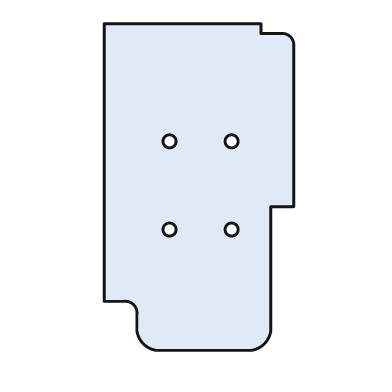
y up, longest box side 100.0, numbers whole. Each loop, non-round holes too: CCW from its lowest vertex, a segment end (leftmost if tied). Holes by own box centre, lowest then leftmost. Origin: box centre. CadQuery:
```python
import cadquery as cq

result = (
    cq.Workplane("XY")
    .moveTo(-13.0, -50.0)
    .lineTo(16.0, -50.0)
    .threePointArc((20.0, -48.0), (22.0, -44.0))
    .lineTo(22.0, -6.0)
    .lineTo(29.0, -6.0)
    .lineTo(29.0, 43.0)
    .threePointArc((28.0, 46.0), (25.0, 47.0))
    .lineTo(19.0, 47.0)
    .lineTo(19.0, 50.0)
    .lineTo(-29.0, 50.0)
    .lineTo(-29.0, -35.0)
    .lineTo(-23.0, -35.0)
    .threePointArc((-20.0, -36.0), (-19.0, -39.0))
    .lineTo(-19.0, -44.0)
    .threePointArc((-17.0, -48.0), (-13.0, -50.0))
    .close()
    .moveTo(-9.0, -13.0)
    .circle(2.0)
    .moveTo(10.0, -13.0)
    .circle(2.0)
    .moveTo(-9.0, 14.0)
    .circle(2.0)
    .moveTo(10.0, 14.0)
    .circle(2.0)
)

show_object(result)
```